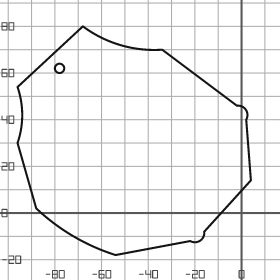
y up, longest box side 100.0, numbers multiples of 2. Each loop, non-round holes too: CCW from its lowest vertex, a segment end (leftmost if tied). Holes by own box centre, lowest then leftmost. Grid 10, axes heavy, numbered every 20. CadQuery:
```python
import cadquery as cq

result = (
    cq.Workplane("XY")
    .moveTo(-54.0, -18.0)
    .lineTo(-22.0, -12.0)
    .threePointArc((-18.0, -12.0), (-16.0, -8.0))
    .lineTo(4.0, 14.0)
    .lineTo(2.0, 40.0)
    .threePointArc((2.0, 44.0), (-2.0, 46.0))
    .lineTo(-34.0, 70.0)
    .threePointArc((-52.0, 72.0), (-68.0, 80.0))
    .lineTo(-96.0, 54.0)
    .threePointArc((-94.0, 42.0), (-96.0, 30.0))
    .lineTo(-88.0, 2.0)
    .threePointArc((-72.0, -10.0), (-54.0, -18.0))
    .close()
    .moveTo(-78.0, 62.0)
    .circle(2.0)
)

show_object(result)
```